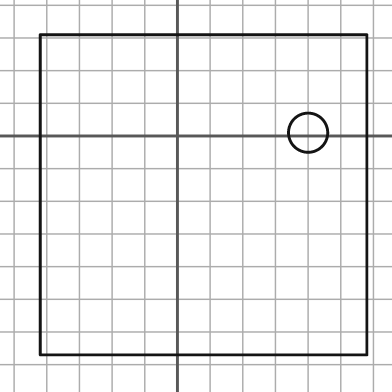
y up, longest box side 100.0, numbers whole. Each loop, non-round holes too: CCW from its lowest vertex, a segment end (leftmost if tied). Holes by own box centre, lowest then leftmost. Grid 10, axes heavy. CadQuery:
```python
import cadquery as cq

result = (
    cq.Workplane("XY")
    .moveTo(-42.0, -67.0)
    .lineTo(58.0, -67.0)
    .lineTo(58.0, 31.0)
    .lineTo(-42.0, 31.0)
    .close()
    .moveTo(40.0, 1.0)
    .circle(6.0)
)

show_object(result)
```